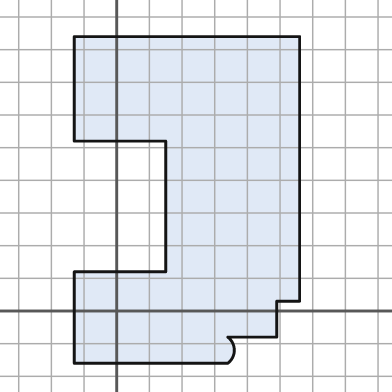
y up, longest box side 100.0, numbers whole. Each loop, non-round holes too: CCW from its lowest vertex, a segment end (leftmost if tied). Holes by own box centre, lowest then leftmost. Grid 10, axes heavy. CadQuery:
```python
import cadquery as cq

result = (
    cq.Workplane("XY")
    .moveTo(-13.0, -16.0)
    .lineTo(34.0, -16.0)
    .threePointArc((36.0, -12.0), (34.0, -8.0))
    .lineTo(49.0, -8.0)
    .lineTo(49.0, 3.0)
    .lineTo(56.0, 3.0)
    .lineTo(56.0, 84.0)
    .lineTo(-13.0, 84.0)
    .lineTo(-13.0, 52.0)
    .lineTo(15.0, 52.0)
    .lineTo(15.0, 12.0)
    .lineTo(-13.0, 12.0)
    .close()
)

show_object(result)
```